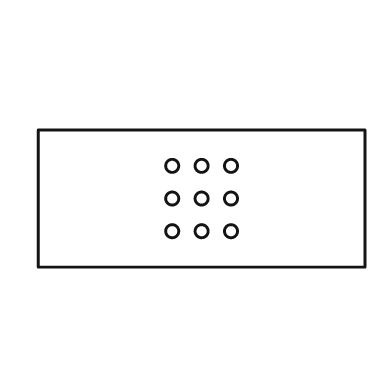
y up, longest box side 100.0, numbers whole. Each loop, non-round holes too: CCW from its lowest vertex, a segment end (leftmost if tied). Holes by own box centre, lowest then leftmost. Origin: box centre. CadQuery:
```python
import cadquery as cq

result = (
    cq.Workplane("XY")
    .moveTo(-50.0, -21.0)
    .lineTo(50.0, -21.0)
    .lineTo(50.0, 21.0)
    .lineTo(-50.0, 21.0)
    .close()
    .moveTo(-9.0, -10.0)
    .circle(2.0)
    .moveTo(0.0, -10.0)
    .circle(2.0)
    .moveTo(9.0, -10.0)
    .circle(2.0)
    .moveTo(-9.0, 0.0)
    .circle(2.0)
    .moveTo(0.0, 0.0)
    .circle(2.0)
    .moveTo(9.0, 0.0)
    .circle(2.0)
    .moveTo(-9.0, 10.0)
    .circle(2.0)
    .moveTo(0.0, 10.0)
    .circle(2.0)
    .moveTo(9.0, 10.0)
    .circle(2.0)
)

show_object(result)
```